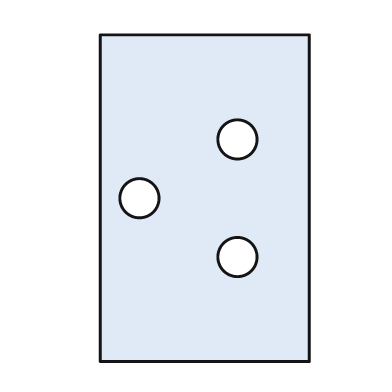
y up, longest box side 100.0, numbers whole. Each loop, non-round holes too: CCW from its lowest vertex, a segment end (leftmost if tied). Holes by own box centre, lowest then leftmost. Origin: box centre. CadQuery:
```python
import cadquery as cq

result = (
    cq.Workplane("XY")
    .moveTo(-32.0, -50.0)
    .lineTo(32.0, -50.0)
    .lineTo(32.0, 50.0)
    .lineTo(-32.0, 50.0)
    .close()
    .moveTo(10.0, -18.0)
    .circle(6.0)
    .moveTo(-20.0, 0.0)
    .circle(6.0)
    .moveTo(10.0, 18.0)
    .circle(6.0)
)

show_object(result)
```